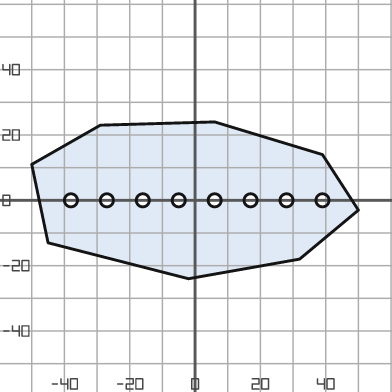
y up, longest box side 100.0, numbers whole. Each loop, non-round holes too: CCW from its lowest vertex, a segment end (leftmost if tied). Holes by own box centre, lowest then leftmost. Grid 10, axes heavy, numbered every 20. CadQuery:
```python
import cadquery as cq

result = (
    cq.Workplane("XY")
    .moveTo(-2.0, -24.0)
    .lineTo(32.0, -18.0)
    .lineTo(50.0, -3.0)
    .lineTo(39.0, 14.0)
    .lineTo(6.0, 24.0)
    .lineTo(-29.0, 23.0)
    .lineTo(-50.0, 11.0)
    .lineTo(-45.0, -13.0)
    .close()
    .moveTo(-38.0, 0.0)
    .circle(2.0)
    .moveTo(-27.0, 0.0)
    .circle(2.0)
    .moveTo(-16.0, 0.0)
    .circle(2.0)
    .moveTo(-5.0, 0.0)
    .circle(2.0)
    .moveTo(6.0, 0.0)
    .circle(2.0)
    .moveTo(17.0, 0.0)
    .circle(2.0)
    .moveTo(28.0, 0.0)
    .circle(2.0)
    .moveTo(39.0, 0.0)
    .circle(2.0)
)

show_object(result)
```